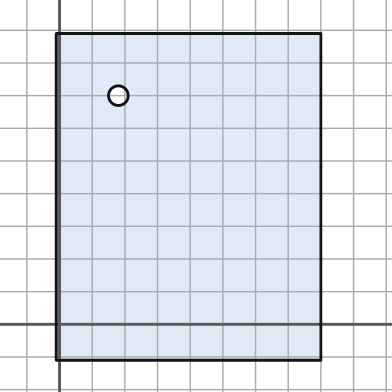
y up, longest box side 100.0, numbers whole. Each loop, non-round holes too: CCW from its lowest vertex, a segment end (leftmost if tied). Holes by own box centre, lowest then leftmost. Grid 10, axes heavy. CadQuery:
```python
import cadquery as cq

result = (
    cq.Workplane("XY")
    .moveTo(-1.0, -11.0)
    .lineTo(80.0, -11.0)
    .lineTo(80.0, 89.0)
    .lineTo(-1.0, 89.0)
    .close()
    .moveTo(18.0, 70.0)
    .circle(3.0)
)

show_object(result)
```